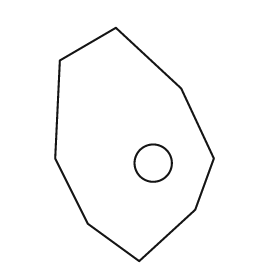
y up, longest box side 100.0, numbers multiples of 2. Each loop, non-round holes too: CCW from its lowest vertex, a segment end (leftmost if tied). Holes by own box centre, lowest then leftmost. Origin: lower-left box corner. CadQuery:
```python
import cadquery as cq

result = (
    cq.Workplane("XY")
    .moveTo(36.0, 0.0)
    .lineTo(60.0, 22.0)
    .lineTo(68.0, 44.0)
    .lineTo(54.0, 74.0)
    .lineTo(26.0, 100.0)
    .lineTo(2.0, 86.0)
    .lineTo(0.0, 44.0)
    .lineTo(14.0, 16.0)
    .close()
    .moveTo(42.0, 42.0)
    .circle(8.0)
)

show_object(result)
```